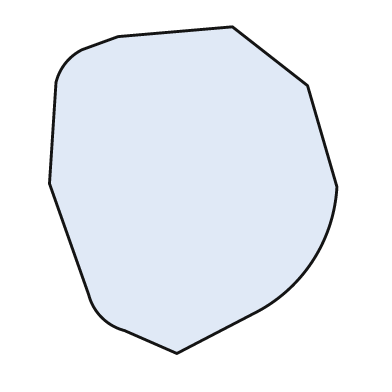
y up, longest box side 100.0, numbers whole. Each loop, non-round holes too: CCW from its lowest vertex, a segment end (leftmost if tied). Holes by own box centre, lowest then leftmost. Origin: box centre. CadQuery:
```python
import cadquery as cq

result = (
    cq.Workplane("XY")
    .moveTo(-5.0, -50.0)
    .lineTo(20.0, -37.0)
    .threePointArc((37.0, -21.0), (44.0, 1.0))
    .lineTo(35.0, 32.0)
    .lineTo(12.0, 50.0)
    .lineTo(-23.0, 47.0)
    .lineTo(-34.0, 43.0)
    .threePointArc((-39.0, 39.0), (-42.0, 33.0))
    .lineTo(-44.0, 2.0)
    .lineTo(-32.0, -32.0)
    .threePointArc((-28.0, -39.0), (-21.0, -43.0))
    .close()
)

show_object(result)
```